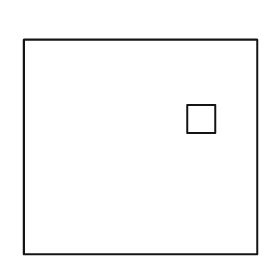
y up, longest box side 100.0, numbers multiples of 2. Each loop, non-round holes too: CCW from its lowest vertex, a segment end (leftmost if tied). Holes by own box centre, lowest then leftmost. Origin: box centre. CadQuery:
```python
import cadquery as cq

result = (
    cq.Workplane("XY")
    .moveTo(-50.0, -46.0)
    .lineTo(50.0, -46.0)
    .lineTo(50.0, 46.0)
    .lineTo(-50.0, 46.0)
    .close()
    .moveTo(20.0, 6.0)
    .lineTo(32.0, 6.0)
    .lineTo(32.0, 18.0)
    .lineTo(20.0, 18.0)
    .close()
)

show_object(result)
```